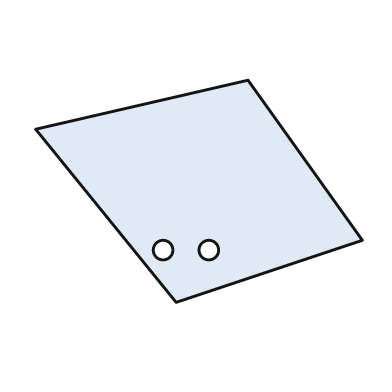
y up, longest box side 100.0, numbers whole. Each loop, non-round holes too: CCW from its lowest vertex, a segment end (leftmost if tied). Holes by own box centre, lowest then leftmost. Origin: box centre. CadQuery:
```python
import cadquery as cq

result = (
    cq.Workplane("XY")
    .moveTo(-7.0, -34.0)
    .lineTo(50.0, -15.0)
    .lineTo(15.0, 34.0)
    .lineTo(-50.0, 19.0)
    .close()
    .moveTo(-11.0, -18.0)
    .circle(3.0)
    .moveTo(3.0, -18.0)
    .circle(3.0)
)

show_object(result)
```